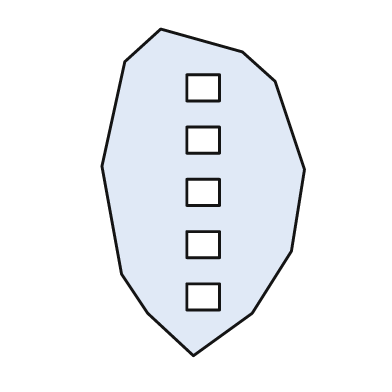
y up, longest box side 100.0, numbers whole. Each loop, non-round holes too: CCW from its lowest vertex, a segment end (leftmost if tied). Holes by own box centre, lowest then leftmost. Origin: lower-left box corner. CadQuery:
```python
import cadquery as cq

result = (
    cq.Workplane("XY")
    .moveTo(28.0, 0.0)
    .lineTo(46.0, 13.0)
    .lineTo(58.0, 32.0)
    .lineTo(62.0, 57.0)
    .lineTo(53.0, 84.0)
    .lineTo(43.0, 93.0)
    .lineTo(18.0, 100.0)
    .lineTo(7.0, 90.0)
    .lineTo(0.0, 58.0)
    .lineTo(6.0, 25.0)
    .lineTo(14.0, 13.0)
    .close()
    .moveTo(26.0, 14.0)
    .lineTo(36.0, 14.0)
    .lineTo(36.0, 22.0)
    .lineTo(26.0, 22.0)
    .close()
    .moveTo(26.0, 30.0)
    .lineTo(36.0, 30.0)
    .lineTo(36.0, 38.0)
    .lineTo(26.0, 38.0)
    .close()
    .moveTo(26.0, 46.0)
    .lineTo(36.0, 46.0)
    .lineTo(36.0, 54.0)
    .lineTo(26.0, 54.0)
    .close()
    .moveTo(26.0, 62.0)
    .lineTo(36.0, 62.0)
    .lineTo(36.0, 70.0)
    .lineTo(26.0, 70.0)
    .close()
    .moveTo(26.0, 78.0)
    .lineTo(36.0, 78.0)
    .lineTo(36.0, 86.0)
    .lineTo(26.0, 86.0)
    .close()
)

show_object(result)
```